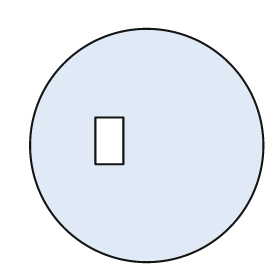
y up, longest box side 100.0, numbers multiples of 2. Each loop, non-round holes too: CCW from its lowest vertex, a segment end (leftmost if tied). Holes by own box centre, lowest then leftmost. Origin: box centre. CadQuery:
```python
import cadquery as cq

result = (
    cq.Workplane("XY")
    .moveTo(0.0, 0.0)
    .circle(50.0)
    .moveTo(-22.0, -8.0)
    .lineTo(-10.0, -8.0)
    .lineTo(-10.0, 12.0)
    .lineTo(-22.0, 12.0)
    .close()
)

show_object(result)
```